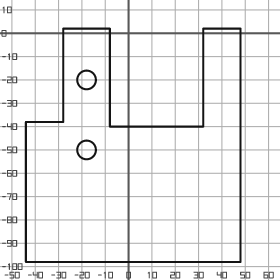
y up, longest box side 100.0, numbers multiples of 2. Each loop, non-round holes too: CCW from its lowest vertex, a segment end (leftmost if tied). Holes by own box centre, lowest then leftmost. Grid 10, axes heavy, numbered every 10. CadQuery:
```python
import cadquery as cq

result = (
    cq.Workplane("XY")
    .moveTo(-44.0, -98.0)
    .lineTo(48.0, -98.0)
    .lineTo(48.0, 2.0)
    .lineTo(32.0, 2.0)
    .lineTo(32.0, -40.0)
    .lineTo(-8.0, -40.0)
    .lineTo(-8.0, 2.0)
    .lineTo(-28.0, 2.0)
    .lineTo(-28.0, -38.0)
    .lineTo(-44.0, -38.0)
    .close()
    .moveTo(-18.0, -50.0)
    .circle(4.0)
    .moveTo(-18.0, -20.0)
    .circle(4.0)
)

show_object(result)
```